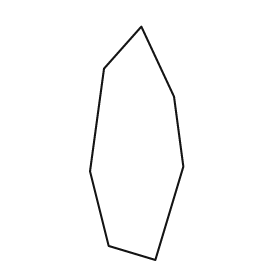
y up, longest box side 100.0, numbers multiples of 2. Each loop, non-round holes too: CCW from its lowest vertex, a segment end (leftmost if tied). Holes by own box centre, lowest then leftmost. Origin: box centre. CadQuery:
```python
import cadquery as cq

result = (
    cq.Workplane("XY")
    .moveTo(8.0, -50.0)
    .lineTo(20.0, -10.0)
    .lineTo(16.0, 20.0)
    .lineTo(2.0, 50.0)
    .lineTo(-14.0, 32.0)
    .lineTo(-20.0, -12.0)
    .lineTo(-12.0, -44.0)
    .close()
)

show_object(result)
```